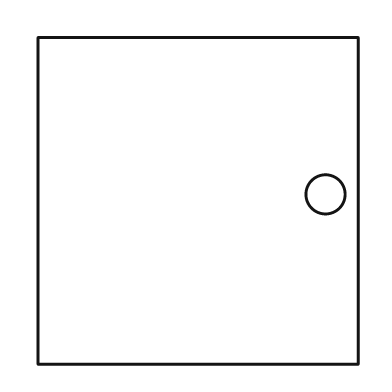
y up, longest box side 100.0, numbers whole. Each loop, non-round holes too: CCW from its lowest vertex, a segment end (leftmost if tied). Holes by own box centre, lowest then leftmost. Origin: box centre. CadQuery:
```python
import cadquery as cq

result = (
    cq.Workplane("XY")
    .moveTo(-49.0, -50.0)
    .lineTo(49.0, -50.0)
    .lineTo(49.0, 50.0)
    .lineTo(-49.0, 50.0)
    .close()
    .moveTo(39.0, 2.0)
    .circle(6.0)
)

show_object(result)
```